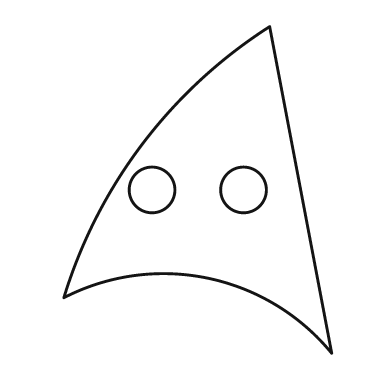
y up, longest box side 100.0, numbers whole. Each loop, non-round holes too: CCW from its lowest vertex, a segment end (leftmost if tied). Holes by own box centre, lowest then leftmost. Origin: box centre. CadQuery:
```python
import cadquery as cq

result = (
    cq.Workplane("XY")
    .moveTo(41.0, -50.0)
    .lineTo(22.0, 50.0)
    .threePointArc((-17.0, 14.0), (-41.0, -33.0))
    .threePointArc((3.0, -27.0), (41.0, -50.0))
    .close()
    .moveTo(-14.0, 0.0)
    .circle(7.0)
    .moveTo(14.0, 0.0)
    .circle(7.0)
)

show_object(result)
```